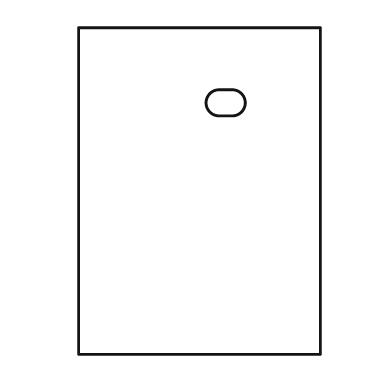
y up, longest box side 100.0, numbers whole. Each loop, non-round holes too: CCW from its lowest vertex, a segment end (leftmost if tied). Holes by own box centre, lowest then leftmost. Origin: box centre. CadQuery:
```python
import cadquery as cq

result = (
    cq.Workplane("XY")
    .moveTo(-37.0, -50.0)
    .lineTo(37.0, -50.0)
    .lineTo(37.0, 50.0)
    .lineTo(-37.0, 50.0)
    .close()
    .moveTo(6.0, 23.0)
    .lineTo(10.0, 23.0)
    .threePointArc((14.0, 27.0), (10.0, 31.0))
    .lineTo(6.0, 31.0)
    .threePointArc((2.0, 27.0), (6.0, 23.0))
    .close()
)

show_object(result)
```